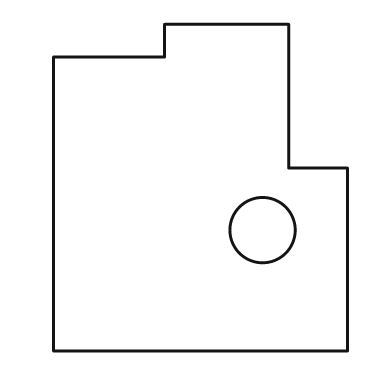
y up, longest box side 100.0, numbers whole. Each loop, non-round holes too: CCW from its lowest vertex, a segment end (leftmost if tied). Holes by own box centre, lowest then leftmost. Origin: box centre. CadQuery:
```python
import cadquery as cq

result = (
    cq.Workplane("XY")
    .moveTo(-45.0, -50.0)
    .lineTo(45.0, -50.0)
    .lineTo(45.0, 6.0)
    .lineTo(27.0, 6.0)
    .lineTo(27.0, 50.0)
    .lineTo(-11.0, 50.0)
    .lineTo(-11.0, 40.0)
    .lineTo(-45.0, 40.0)
    .close()
    .moveTo(19.0, -13.0)
    .circle(10.0)
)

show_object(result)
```